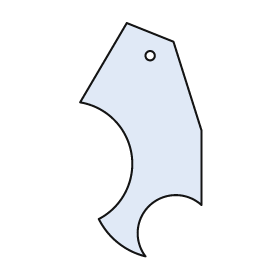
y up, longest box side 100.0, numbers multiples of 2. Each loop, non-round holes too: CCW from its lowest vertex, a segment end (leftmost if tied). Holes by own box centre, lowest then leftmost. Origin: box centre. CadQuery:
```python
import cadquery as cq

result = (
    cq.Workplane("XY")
    .moveTo(2.0, -50.0)
    .threePointArc((4.0, -28.0), (26.0, -28.0))
    .lineTo(26.0, 4.0)
    .lineTo(14.0, 42.0)
    .lineTo(-6.0, 50.0)
    .lineTo(-26.0, 16.0)
    .threePointArc((-4.0, -6.0), (-18.0, -34.0))
    .threePointArc((-10.0, -44.0), (2.0, -50.0))
    .close()
    .moveTo(4.0, 36.0)
    .circle(2.0)
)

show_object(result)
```